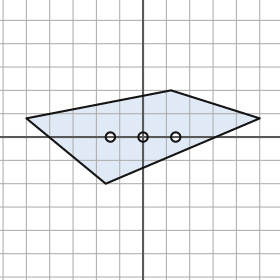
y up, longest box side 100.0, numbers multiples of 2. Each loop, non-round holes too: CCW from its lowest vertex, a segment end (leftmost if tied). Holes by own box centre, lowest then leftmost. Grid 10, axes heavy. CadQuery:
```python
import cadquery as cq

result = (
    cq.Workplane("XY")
    .moveTo(-16.0, -20.0)
    .lineTo(50.0, 8.0)
    .lineTo(12.0, 20.0)
    .lineTo(-50.0, 8.0)
    .close()
    .moveTo(-14.0, 0.0)
    .circle(2.0)
    .moveTo(0.0, 0.0)
    .circle(2.0)
    .moveTo(14.0, 0.0)
    .circle(2.0)
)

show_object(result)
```